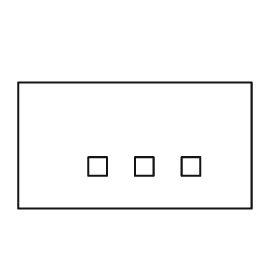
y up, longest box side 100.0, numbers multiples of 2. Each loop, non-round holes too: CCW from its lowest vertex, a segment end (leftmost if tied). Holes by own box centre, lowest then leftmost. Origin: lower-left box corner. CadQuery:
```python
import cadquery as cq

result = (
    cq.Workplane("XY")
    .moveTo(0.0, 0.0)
    .lineTo(100.0, 0.0)
    .lineTo(100.0, 54.0)
    .lineTo(0.0, 54.0)
    .close()
    .moveTo(30.0, 14.0)
    .lineTo(38.0, 14.0)
    .lineTo(38.0, 22.0)
    .lineTo(30.0, 22.0)
    .close()
    .moveTo(50.0, 14.0)
    .lineTo(58.0, 14.0)
    .lineTo(58.0, 22.0)
    .lineTo(50.0, 22.0)
    .close()
    .moveTo(70.0, 14.0)
    .lineTo(78.0, 14.0)
    .lineTo(78.0, 22.0)
    .lineTo(70.0, 22.0)
    .close()
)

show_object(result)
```